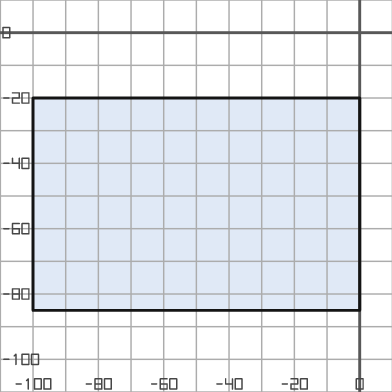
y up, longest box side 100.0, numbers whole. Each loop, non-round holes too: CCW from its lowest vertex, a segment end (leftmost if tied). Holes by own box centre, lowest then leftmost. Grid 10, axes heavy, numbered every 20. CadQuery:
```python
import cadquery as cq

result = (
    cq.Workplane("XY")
    .moveTo(-100.0, -85.0)
    .lineTo(0.0, -85.0)
    .lineTo(0.0, -20.0)
    .lineTo(-100.0, -20.0)
    .close()
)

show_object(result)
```